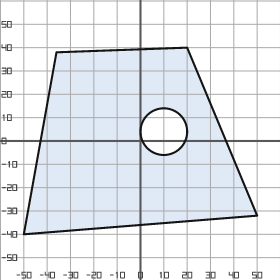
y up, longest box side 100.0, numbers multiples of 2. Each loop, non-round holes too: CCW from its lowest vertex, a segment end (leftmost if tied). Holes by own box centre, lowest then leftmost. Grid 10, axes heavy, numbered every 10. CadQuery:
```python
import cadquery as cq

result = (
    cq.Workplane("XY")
    .moveTo(-50.0, -40.0)
    .lineTo(50.0, -32.0)
    .lineTo(20.0, 40.0)
    .lineTo(-36.0, 38.0)
    .close()
    .moveTo(10.0, 4.0)
    .circle(10.0)
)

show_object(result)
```